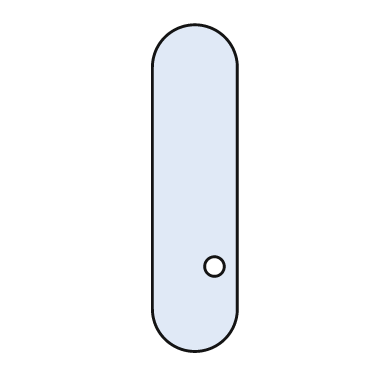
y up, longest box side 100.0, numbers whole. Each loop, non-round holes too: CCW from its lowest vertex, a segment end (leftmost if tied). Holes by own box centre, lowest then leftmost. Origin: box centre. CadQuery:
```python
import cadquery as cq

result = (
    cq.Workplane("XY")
    .moveTo(-13.0, -37.0)
    .threePointArc((0.0, -50.0), (13.0, -37.0))
    .lineTo(13.0, 37.0)
    .threePointArc((0.0, 50.0), (-13.0, 37.0))
    .close()
    .moveTo(6.0, -24.0)
    .circle(3.0)
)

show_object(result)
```